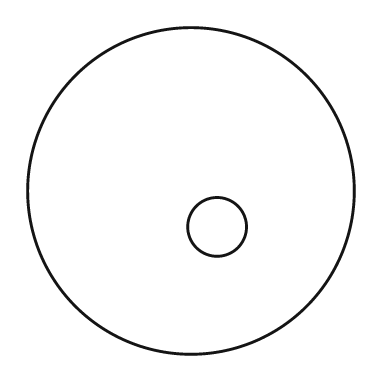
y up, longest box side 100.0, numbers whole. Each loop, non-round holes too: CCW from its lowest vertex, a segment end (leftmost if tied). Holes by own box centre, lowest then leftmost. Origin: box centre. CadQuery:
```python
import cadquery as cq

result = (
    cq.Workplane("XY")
    .moveTo(0.0, 0.0)
    .circle(50.0)
    .moveTo(8.0, -11.0)
    .circle(9.0)
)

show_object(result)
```